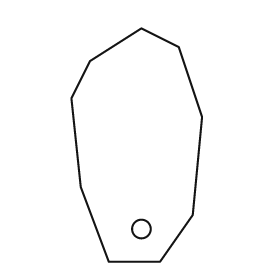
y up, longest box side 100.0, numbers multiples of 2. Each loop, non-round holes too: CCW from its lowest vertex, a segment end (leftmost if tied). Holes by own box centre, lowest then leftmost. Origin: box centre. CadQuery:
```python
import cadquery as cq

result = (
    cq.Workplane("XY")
    .moveTo(-12.0, -50.0)
    .lineTo(10.0, -50.0)
    .lineTo(24.0, -30.0)
    .lineTo(28.0, 12.0)
    .lineTo(18.0, 42.0)
    .lineTo(2.0, 50.0)
    .lineTo(-20.0, 36.0)
    .lineTo(-28.0, 20.0)
    .lineTo(-24.0, -18.0)
    .close()
    .moveTo(2.0, -36.0)
    .circle(4.0)
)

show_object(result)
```